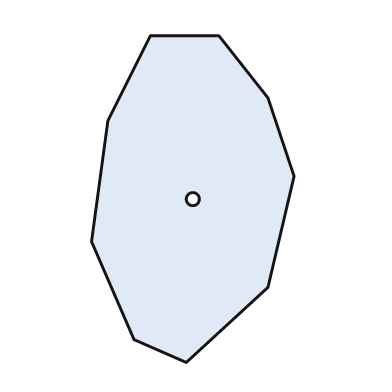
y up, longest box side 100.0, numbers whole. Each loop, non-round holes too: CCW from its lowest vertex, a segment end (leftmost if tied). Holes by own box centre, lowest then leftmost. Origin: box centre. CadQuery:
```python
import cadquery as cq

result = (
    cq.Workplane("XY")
    .moveTo(-2.0, -50.0)
    .lineTo(23.0, -27.0)
    .lineTo(31.0, 7.0)
    .lineTo(23.0, 31.0)
    .lineTo(8.0, 50.0)
    .lineTo(-13.0, 50.0)
    .lineTo(-26.0, 24.0)
    .lineTo(-31.0, -13.0)
    .lineTo(-18.0, -43.0)
    .close()
    .moveTo(0.0, 0.0)
    .circle(2.0)
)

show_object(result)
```